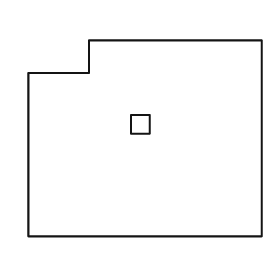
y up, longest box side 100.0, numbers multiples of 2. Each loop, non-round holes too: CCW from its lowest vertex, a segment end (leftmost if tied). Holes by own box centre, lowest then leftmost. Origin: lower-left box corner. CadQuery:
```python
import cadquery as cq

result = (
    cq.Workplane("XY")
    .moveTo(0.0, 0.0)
    .lineTo(100.0, 0.0)
    .lineTo(100.0, 84.0)
    .lineTo(26.0, 84.0)
    .lineTo(26.0, 70.0)
    .lineTo(0.0, 70.0)
    .close()
    .moveTo(44.0, 44.0)
    .lineTo(52.0, 44.0)
    .lineTo(52.0, 52.0)
    .lineTo(44.0, 52.0)
    .close()
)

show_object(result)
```